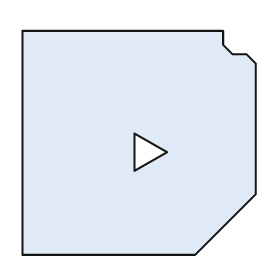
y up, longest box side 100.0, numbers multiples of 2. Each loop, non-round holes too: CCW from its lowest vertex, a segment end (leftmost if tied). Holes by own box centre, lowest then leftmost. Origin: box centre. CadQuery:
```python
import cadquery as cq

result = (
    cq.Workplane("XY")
    .moveTo(-50.0, -48.0)
    .lineTo(24.0, -48.0)
    .lineTo(50.0, -22.0)
    .lineTo(50.0, 34.0)
    .lineTo(46.0, 38.0)
    .lineTo(40.0, 38.0)
    .lineTo(36.0, 42.0)
    .lineTo(36.0, 48.0)
    .lineTo(-50.0, 48.0)
    .close()
    .moveTo(-2.0, -12.0)
    .lineTo(12.0, -4.0)
    .lineTo(-2.0, 4.0)
    .close()
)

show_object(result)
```